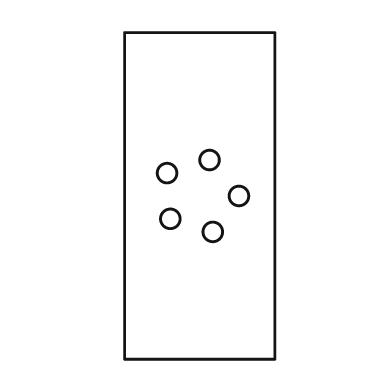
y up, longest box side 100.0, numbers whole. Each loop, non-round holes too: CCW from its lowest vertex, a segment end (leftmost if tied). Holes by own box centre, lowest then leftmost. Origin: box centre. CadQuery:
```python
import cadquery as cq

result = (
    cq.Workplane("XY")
    .moveTo(-23.0, -50.0)
    .lineTo(23.0, -50.0)
    .lineTo(23.0, 50.0)
    .lineTo(-23.0, 50.0)
    .close()
    .moveTo(4.0, -11.0)
    .circle(3.0)
    .moveTo(-9.0, -7.0)
    .circle(3.0)
    .moveTo(12.0, 0.0)
    .circle(3.0)
    .moveTo(-10.0, 7.0)
    .circle(3.0)
    .moveTo(3.0, 11.0)
    .circle(3.0)
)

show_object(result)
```